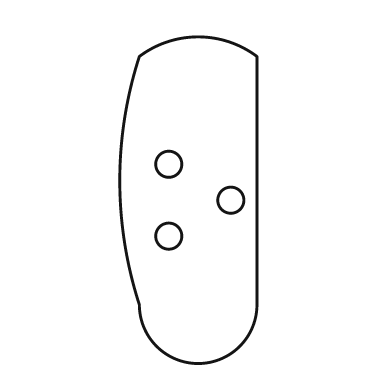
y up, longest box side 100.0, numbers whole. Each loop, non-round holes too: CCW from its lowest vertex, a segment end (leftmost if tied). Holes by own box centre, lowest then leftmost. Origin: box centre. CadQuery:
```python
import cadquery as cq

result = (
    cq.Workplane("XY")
    .moveTo(-15.0, -32.0)
    .threePointArc((3.0, -50.0), (21.0, -32.0))
    .lineTo(21.0, 44.0)
    .threePointArc((3.0, 50.0), (-15.0, 44.0))
    .threePointArc((-21.0, 6.0), (-15.0, -32.0))
    .close()
    .moveTo(-6.0, -11.0)
    .circle(4.0)
    .moveTo(13.0, 0.0)
    .circle(4.0)
    .moveTo(-6.0, 11.0)
    .circle(4.0)
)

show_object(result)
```